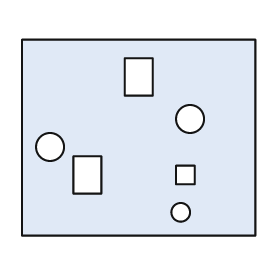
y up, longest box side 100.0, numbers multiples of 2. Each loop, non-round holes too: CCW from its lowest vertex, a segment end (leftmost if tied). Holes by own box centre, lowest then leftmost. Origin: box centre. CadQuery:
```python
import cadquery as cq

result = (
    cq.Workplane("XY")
    .moveTo(-50.0, -42.0)
    .lineTo(50.0, -42.0)
    .lineTo(50.0, 42.0)
    .lineTo(-50.0, 42.0)
    .close()
    .moveTo(18.0, -32.0)
    .circle(4.0)
    .moveTo(-28.0, -24.0)
    .lineTo(-16.0, -24.0)
    .lineTo(-16.0, -8.0)
    .lineTo(-28.0, -8.0)
    .close()
    .moveTo(16.0, -20.0)
    .lineTo(24.0, -20.0)
    .lineTo(24.0, -12.0)
    .lineTo(16.0, -12.0)
    .close()
    .moveTo(-38.0, -4.0)
    .circle(6.0)
    .moveTo(22.0, 8.0)
    .circle(6.0)
    .moveTo(-6.0, 18.0)
    .lineTo(6.0, 18.0)
    .lineTo(6.0, 34.0)
    .lineTo(-6.0, 34.0)
    .close()
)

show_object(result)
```